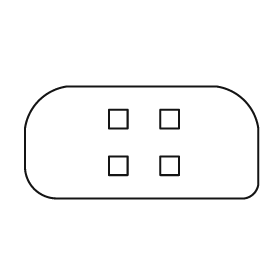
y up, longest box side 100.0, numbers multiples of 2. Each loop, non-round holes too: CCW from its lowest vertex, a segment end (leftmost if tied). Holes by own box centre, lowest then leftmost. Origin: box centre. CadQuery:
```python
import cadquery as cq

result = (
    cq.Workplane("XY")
    .moveTo(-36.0, -24.0)
    .lineTo(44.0, -24.0)
    .threePointArc((48.0, -22.0), (50.0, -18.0))
    .lineTo(50.0, 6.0)
    .threePointArc((44.0, 18.0), (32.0, 24.0))
    .lineTo(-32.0, 24.0)
    .threePointArc((-44.0, 18.0), (-50.0, 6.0))
    .lineTo(-50.0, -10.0)
    .threePointArc((-46.0, -20.0), (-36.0, -24.0))
    .close()
    .moveTo(-14.0, -14.0)
    .lineTo(-6.0, -14.0)
    .lineTo(-6.0, -6.0)
    .lineTo(-14.0, -6.0)
    .close()
    .moveTo(8.0, -14.0)
    .lineTo(16.0, -14.0)
    .lineTo(16.0, -6.0)
    .lineTo(8.0, -6.0)
    .close()
    .moveTo(-14.0, 6.0)
    .lineTo(-6.0, 6.0)
    .lineTo(-6.0, 14.0)
    .lineTo(-14.0, 14.0)
    .close()
    .moveTo(8.0, 6.0)
    .lineTo(16.0, 6.0)
    .lineTo(16.0, 14.0)
    .lineTo(8.0, 14.0)
    .close()
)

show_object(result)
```